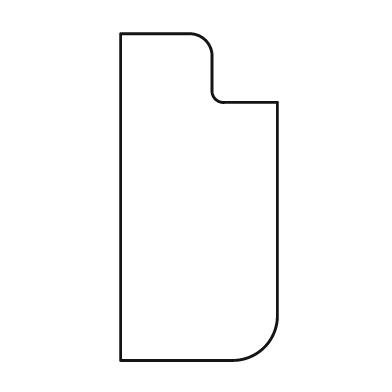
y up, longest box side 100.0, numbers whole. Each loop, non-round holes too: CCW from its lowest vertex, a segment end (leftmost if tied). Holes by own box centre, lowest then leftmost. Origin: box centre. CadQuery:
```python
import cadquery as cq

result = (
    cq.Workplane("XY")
    .moveTo(-24.0, -50.0)
    .lineTo(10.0, -50.0)
    .threePointArc((20.0, -46.0), (24.0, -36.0))
    .lineTo(24.0, 29.0)
    .lineTo(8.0, 29.0)
    .threePointArc((5.0, 30.0), (4.0, 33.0))
    .lineTo(4.0, 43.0)
    .threePointArc((2.0, 48.0), (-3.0, 50.0))
    .lineTo(-24.0, 50.0)
    .close()
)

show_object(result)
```